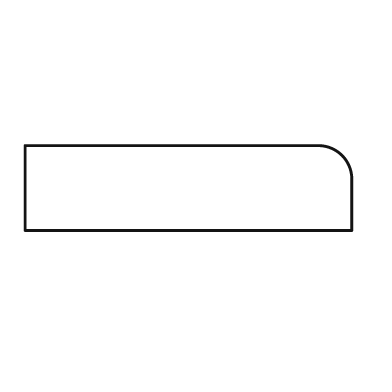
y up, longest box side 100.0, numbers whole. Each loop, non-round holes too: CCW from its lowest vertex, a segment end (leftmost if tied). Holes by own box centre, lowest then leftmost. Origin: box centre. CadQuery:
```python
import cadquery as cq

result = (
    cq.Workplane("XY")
    .moveTo(-50.0, -13.0)
    .lineTo(50.0, -13.0)
    .lineTo(50.0, 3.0)
    .threePointArc((47.0, 10.0), (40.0, 13.0))
    .lineTo(-50.0, 13.0)
    .close()
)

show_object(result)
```